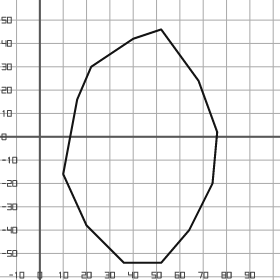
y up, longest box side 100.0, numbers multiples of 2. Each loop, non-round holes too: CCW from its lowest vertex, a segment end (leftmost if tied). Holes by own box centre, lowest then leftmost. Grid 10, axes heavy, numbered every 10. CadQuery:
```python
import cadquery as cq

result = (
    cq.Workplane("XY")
    .moveTo(36.0, -54.0)
    .lineTo(52.0, -54.0)
    .lineTo(64.0, -40.0)
    .lineTo(74.0, -20.0)
    .lineTo(76.0, 2.0)
    .lineTo(68.0, 24.0)
    .lineTo(52.0, 46.0)
    .lineTo(40.0, 42.0)
    .lineTo(22.0, 30.0)
    .lineTo(16.0, 16.0)
    .lineTo(10.0, -16.0)
    .lineTo(20.0, -38.0)
    .close()
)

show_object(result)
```